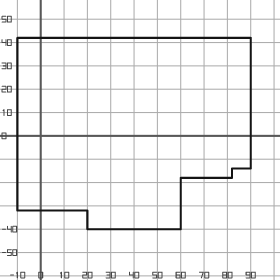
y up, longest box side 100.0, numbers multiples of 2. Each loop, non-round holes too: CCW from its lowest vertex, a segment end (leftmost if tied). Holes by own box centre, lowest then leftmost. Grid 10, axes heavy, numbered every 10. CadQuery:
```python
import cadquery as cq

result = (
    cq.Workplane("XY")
    .moveTo(20.0, -40.0)
    .lineTo(60.0, -40.0)
    .lineTo(60.0, -18.0)
    .lineTo(82.0, -18.0)
    .lineTo(82.0, -14.0)
    .lineTo(90.0, -14.0)
    .lineTo(90.0, 42.0)
    .lineTo(-10.0, 42.0)
    .lineTo(-10.0, -32.0)
    .lineTo(20.0, -32.0)
    .close()
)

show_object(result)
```